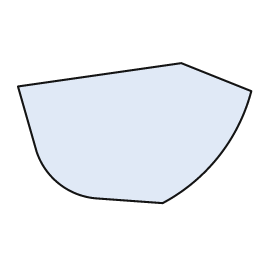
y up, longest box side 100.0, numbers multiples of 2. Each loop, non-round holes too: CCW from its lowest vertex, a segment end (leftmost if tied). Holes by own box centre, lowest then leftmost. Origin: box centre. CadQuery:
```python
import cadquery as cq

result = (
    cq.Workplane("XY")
    .moveTo(12.0, -30.0)
    .threePointArc((36.0, -10.0), (50.0, 18.0))
    .lineTo(20.0, 30.0)
    .lineTo(-50.0, 20.0)
    .lineTo(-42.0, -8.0)
    .threePointArc((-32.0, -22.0), (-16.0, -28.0))
    .close()
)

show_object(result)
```